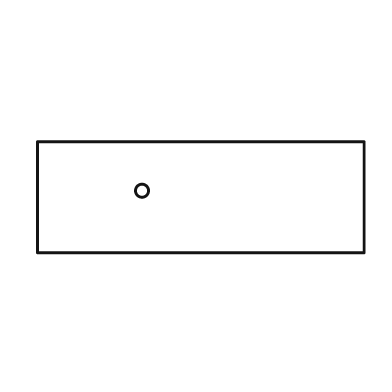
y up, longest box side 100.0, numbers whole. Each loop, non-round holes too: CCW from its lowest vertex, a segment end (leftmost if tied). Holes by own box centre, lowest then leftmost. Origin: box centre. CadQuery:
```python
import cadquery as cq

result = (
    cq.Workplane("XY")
    .moveTo(-50.0, -17.0)
    .lineTo(50.0, -17.0)
    .lineTo(50.0, 17.0)
    .lineTo(-50.0, 17.0)
    .close()
    .moveTo(-18.0, 2.0)
    .circle(2.0)
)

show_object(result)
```